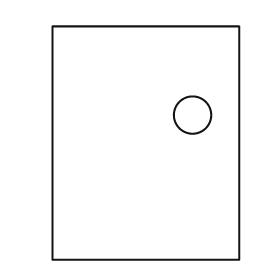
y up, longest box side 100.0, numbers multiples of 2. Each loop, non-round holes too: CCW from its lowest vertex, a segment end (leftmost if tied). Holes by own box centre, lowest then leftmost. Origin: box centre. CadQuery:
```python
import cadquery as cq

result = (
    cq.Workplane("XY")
    .moveTo(-40.0, -50.0)
    .lineTo(40.0, -50.0)
    .lineTo(40.0, 50.0)
    .lineTo(-40.0, 50.0)
    .close()
    .moveTo(20.0, 12.0)
    .circle(8.0)
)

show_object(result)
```